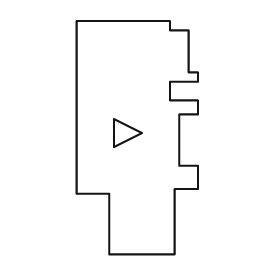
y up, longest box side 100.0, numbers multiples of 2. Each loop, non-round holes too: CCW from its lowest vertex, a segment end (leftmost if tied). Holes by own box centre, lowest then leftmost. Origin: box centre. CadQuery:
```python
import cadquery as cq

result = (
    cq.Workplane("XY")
    .moveTo(-12.0, -50.0)
    .lineTo(16.0, -50.0)
    .lineTo(16.0, -22.0)
    .lineTo(26.0, -22.0)
    .lineTo(26.0, -12.0)
    .lineTo(18.0, -12.0)
    .lineTo(18.0, 10.0)
    .lineTo(26.0, 10.0)
    .lineTo(26.0, 16.0)
    .lineTo(14.0, 16.0)
    .lineTo(14.0, 24.0)
    .lineTo(26.0, 24.0)
    .lineTo(26.0, 28.0)
    .lineTo(22.0, 28.0)
    .lineTo(22.0, 46.0)
    .lineTo(14.0, 46.0)
    .lineTo(14.0, 50.0)
    .lineTo(-26.0, 50.0)
    .lineTo(-26.0, -24.0)
    .lineTo(-12.0, -24.0)
    .close()
    .moveTo(-10.0, -4.0)
    .lineTo(2.0, 2.0)
    .lineTo(-10.0, 8.0)
    .close()
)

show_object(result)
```